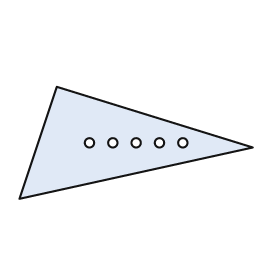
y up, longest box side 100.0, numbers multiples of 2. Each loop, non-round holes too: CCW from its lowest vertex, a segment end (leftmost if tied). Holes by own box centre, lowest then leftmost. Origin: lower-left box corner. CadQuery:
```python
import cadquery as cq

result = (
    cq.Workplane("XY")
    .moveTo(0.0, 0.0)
    .lineTo(100.0, 22.0)
    .lineTo(16.0, 48.0)
    .close()
    .moveTo(30.0, 24.0)
    .circle(2.0)
    .moveTo(40.0, 24.0)
    .circle(2.0)
    .moveTo(50.0, 24.0)
    .circle(2.0)
    .moveTo(60.0, 24.0)
    .circle(2.0)
    .moveTo(70.0, 24.0)
    .circle(2.0)
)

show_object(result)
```